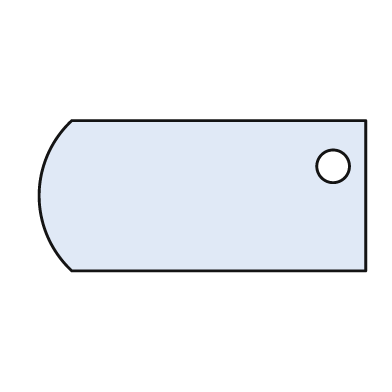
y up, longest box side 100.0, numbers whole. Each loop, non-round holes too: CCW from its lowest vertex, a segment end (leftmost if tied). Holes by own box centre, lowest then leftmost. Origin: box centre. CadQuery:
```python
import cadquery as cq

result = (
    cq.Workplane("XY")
    .moveTo(-40.0, -23.0)
    .lineTo(50.0, -23.0)
    .lineTo(50.0, 23.0)
    .lineTo(-40.0, 23.0)
    .threePointArc((-50.0, 0.0), (-40.0, -23.0))
    .close()
    .moveTo(40.0, 9.0)
    .circle(5.0)
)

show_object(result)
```